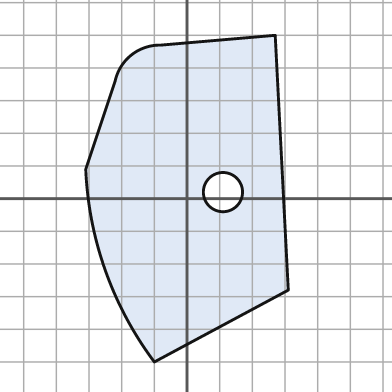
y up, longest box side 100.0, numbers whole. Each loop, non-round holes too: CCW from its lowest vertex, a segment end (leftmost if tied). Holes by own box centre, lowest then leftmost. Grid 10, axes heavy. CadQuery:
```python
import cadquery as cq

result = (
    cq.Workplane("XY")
    .moveTo(-10.0, -50.0)
    .lineTo(31.0, -28.0)
    .lineTo(27.0, 50.0)
    .lineTo(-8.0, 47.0)
    .threePointArc((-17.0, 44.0), (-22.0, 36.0))
    .lineTo(-31.0, 9.0)
    .threePointArc((-25.0, -22.0), (-10.0, -50.0))
    .close()
    .moveTo(11.0, 2.0)
    .circle(6.0)
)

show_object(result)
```